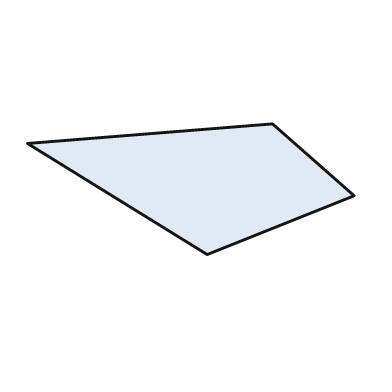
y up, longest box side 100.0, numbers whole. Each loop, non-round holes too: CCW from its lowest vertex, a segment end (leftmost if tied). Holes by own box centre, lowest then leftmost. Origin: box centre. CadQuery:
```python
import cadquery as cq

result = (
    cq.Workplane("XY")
    .moveTo(5.0, -20.0)
    .lineTo(50.0, -2.0)
    .lineTo(25.0, 20.0)
    .lineTo(-50.0, 14.0)
    .close()
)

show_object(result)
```